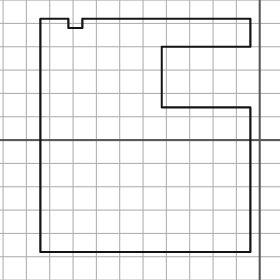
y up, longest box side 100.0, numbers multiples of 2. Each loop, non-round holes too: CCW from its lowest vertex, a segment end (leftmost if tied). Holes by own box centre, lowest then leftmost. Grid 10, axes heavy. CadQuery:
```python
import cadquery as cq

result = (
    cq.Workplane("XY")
    .moveTo(-94.0, -48.0)
    .lineTo(-4.0, -48.0)
    .lineTo(-4.0, 14.0)
    .lineTo(-42.0, 14.0)
    .lineTo(-42.0, 40.0)
    .lineTo(-4.0, 40.0)
    .lineTo(-4.0, 52.0)
    .lineTo(-76.0, 52.0)
    .lineTo(-76.0, 48.0)
    .lineTo(-82.0, 48.0)
    .lineTo(-82.0, 52.0)
    .lineTo(-94.0, 52.0)
    .close()
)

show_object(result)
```